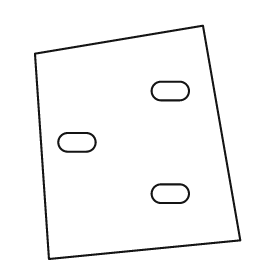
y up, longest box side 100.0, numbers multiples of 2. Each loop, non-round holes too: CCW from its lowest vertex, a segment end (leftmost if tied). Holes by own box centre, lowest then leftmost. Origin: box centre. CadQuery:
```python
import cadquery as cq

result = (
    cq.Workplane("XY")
    .moveTo(-38.0, -50.0)
    .lineTo(44.0, -42.0)
    .lineTo(28.0, 50.0)
    .lineTo(-44.0, 38.0)
    .close()
    .moveTo(10.0, -26.0)
    .lineTo(18.0, -26.0)
    .threePointArc((22.0, -22.0), (18.0, -18.0))
    .lineTo(10.0, -18.0)
    .threePointArc((6.0, -22.0), (10.0, -26.0))
    .close()
    .moveTo(-30.0, -4.0)
    .lineTo(-22.0, -4.0)
    .threePointArc((-18.0, 0.0), (-22.0, 4.0))
    .lineTo(-30.0, 4.0)
    .threePointArc((-34.0, 0.0), (-30.0, -4.0))
    .close()
    .moveTo(10.0, 18.0)
    .lineTo(18.0, 18.0)
    .threePointArc((22.0, 22.0), (18.0, 26.0))
    .lineTo(10.0, 26.0)
    .threePointArc((6.0, 22.0), (10.0, 18.0))
    .close()
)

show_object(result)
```